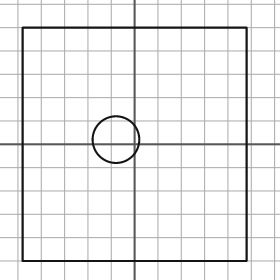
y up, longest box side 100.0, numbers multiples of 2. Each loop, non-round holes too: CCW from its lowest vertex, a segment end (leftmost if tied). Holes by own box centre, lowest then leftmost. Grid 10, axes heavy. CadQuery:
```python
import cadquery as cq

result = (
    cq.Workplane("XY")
    .moveTo(-48.0, -50.0)
    .lineTo(48.0, -50.0)
    .lineTo(48.0, 50.0)
    .lineTo(-48.0, 50.0)
    .close()
    .moveTo(-8.0, 2.0)
    .circle(10.0)
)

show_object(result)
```